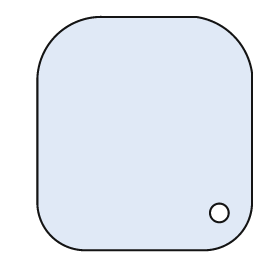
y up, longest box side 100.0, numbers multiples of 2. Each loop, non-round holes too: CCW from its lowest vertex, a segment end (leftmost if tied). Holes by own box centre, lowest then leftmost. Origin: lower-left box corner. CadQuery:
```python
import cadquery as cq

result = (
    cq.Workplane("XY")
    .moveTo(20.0, 0.0)
    .lineTo(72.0, 0.0)
    .threePointArc((86.0, 6.0), (92.0, 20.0))
    .lineTo(92.0, 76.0)
    .threePointArc((84.0, 92.0), (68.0, 100.0))
    .lineTo(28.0, 100.0)
    .threePointArc((8.0, 92.0), (0.0, 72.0))
    .lineTo(0.0, 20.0)
    .threePointArc((6.0, 6.0), (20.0, 0.0))
    .close()
    .moveTo(78.0, 16.0)
    .circle(4.0)
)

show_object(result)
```